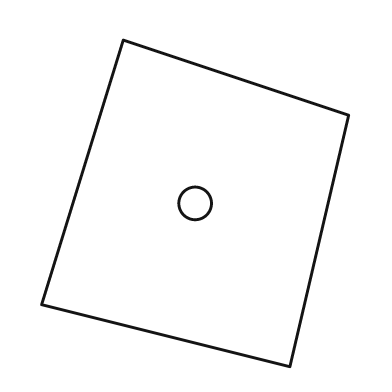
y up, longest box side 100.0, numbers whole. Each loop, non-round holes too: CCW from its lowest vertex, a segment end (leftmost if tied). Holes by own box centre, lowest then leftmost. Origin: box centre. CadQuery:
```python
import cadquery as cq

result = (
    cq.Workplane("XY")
    .moveTo(29.0, -50.0)
    .lineTo(47.0, 27.0)
    .lineTo(-22.0, 50.0)
    .lineTo(-47.0, -31.0)
    .close()
    .moveTo(0.0, 0.0)
    .circle(5.0)
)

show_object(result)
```